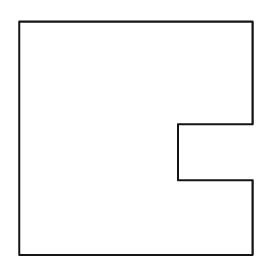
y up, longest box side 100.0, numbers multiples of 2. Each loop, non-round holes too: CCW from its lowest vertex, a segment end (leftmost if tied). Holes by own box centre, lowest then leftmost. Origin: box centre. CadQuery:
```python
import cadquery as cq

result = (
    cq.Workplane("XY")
    .moveTo(-50.0, -50.0)
    .lineTo(50.0, -50.0)
    .lineTo(50.0, -18.0)
    .lineTo(18.0, -18.0)
    .lineTo(18.0, 6.0)
    .lineTo(50.0, 6.0)
    .lineTo(50.0, 50.0)
    .lineTo(-50.0, 50.0)
    .close()
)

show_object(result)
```